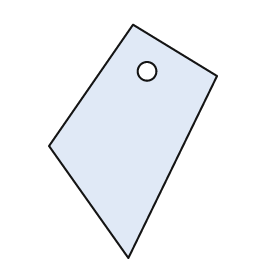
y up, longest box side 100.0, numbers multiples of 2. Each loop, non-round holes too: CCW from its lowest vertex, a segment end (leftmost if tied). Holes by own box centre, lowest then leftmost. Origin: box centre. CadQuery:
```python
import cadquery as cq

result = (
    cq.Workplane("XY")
    .moveTo(-2.0, -50.0)
    .lineTo(36.0, 28.0)
    .lineTo(0.0, 50.0)
    .lineTo(-36.0, -2.0)
    .close()
    .moveTo(6.0, 30.0)
    .circle(4.0)
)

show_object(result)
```